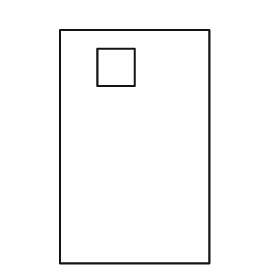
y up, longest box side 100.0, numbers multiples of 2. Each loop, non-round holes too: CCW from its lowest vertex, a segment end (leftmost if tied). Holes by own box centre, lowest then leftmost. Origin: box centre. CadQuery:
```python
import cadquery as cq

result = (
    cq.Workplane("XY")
    .moveTo(-32.0, -50.0)
    .lineTo(32.0, -50.0)
    .lineTo(32.0, 50.0)
    .lineTo(-32.0, 50.0)
    .close()
    .moveTo(-16.0, 26.0)
    .lineTo(0.0, 26.0)
    .lineTo(0.0, 42.0)
    .lineTo(-16.0, 42.0)
    .close()
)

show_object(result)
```